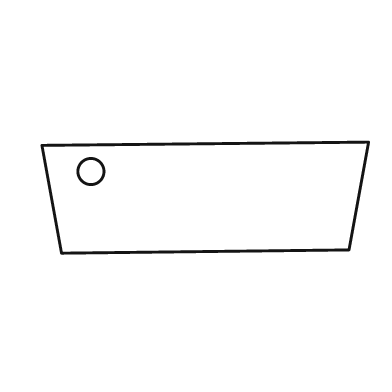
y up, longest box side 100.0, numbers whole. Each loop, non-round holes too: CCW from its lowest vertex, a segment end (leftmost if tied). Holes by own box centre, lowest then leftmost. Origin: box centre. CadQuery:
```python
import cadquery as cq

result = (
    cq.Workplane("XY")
    .moveTo(-44.0, -17.0)
    .lineTo(44.0, -16.0)
    .lineTo(50.0, 17.0)
    .lineTo(-50.0, 16.0)
    .close()
    .moveTo(-35.0, 8.0)
    .circle(4.0)
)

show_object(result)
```